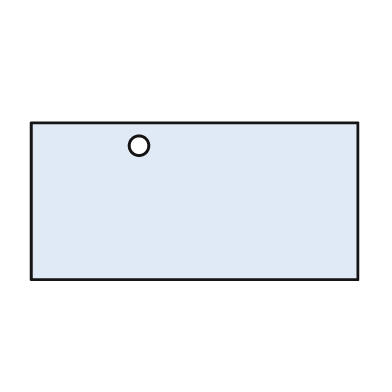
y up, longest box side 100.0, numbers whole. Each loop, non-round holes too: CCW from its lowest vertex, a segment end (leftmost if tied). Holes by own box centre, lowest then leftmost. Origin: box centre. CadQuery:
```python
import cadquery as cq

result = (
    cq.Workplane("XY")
    .moveTo(-50.0, -24.0)
    .lineTo(50.0, -24.0)
    .lineTo(50.0, 24.0)
    .lineTo(-50.0, 24.0)
    .close()
    .moveTo(-17.0, 17.0)
    .circle(3.0)
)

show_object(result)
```